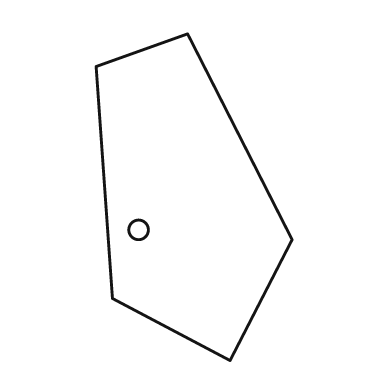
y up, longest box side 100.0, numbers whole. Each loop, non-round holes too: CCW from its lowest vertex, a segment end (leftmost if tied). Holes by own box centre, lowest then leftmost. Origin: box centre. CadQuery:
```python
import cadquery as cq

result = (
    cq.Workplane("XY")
    .moveTo(11.0, -50.0)
    .lineTo(30.0, -13.0)
    .lineTo(-2.0, 50.0)
    .lineTo(-30.0, 40.0)
    .lineTo(-25.0, -31.0)
    .close()
    .moveTo(-17.0, -10.0)
    .circle(3.0)
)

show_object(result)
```